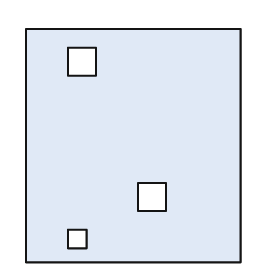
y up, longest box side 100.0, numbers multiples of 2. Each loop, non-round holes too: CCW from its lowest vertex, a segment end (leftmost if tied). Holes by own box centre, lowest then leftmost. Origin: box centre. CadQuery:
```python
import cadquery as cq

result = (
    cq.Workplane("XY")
    .moveTo(-46.0, -50.0)
    .lineTo(46.0, -50.0)
    .lineTo(46.0, 50.0)
    .lineTo(-46.0, 50.0)
    .close()
    .moveTo(-28.0, -44.0)
    .lineTo(-20.0, -44.0)
    .lineTo(-20.0, -36.0)
    .lineTo(-28.0, -36.0)
    .close()
    .moveTo(2.0, -28.0)
    .lineTo(14.0, -28.0)
    .lineTo(14.0, -16.0)
    .lineTo(2.0, -16.0)
    .close()
    .moveTo(-28.0, 30.0)
    .lineTo(-16.0, 30.0)
    .lineTo(-16.0, 42.0)
    .lineTo(-28.0, 42.0)
    .close()
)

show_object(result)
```